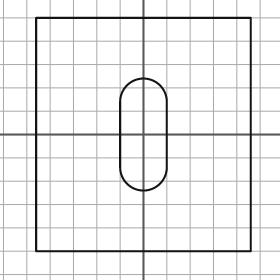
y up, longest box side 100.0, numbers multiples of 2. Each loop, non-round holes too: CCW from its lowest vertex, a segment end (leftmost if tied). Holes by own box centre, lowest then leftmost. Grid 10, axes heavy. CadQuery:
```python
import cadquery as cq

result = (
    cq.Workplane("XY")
    .moveTo(-46.0, -50.0)
    .lineTo(46.0, -50.0)
    .lineTo(46.0, 50.0)
    .lineTo(-46.0, 50.0)
    .close()
    .moveTo(-10.0, -14.0)
    .threePointArc((0.0, -24.0), (10.0, -14.0))
    .lineTo(10.0, 14.0)
    .threePointArc((0.0, 24.0), (-10.0, 14.0))
    .close()
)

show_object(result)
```